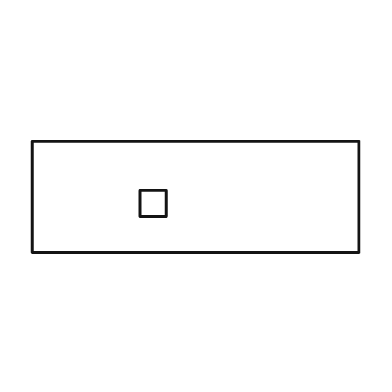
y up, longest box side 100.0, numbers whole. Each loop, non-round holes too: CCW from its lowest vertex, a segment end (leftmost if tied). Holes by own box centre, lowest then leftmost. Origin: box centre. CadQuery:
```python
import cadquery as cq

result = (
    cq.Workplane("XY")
    .moveTo(-50.0, -17.0)
    .lineTo(50.0, -17.0)
    .lineTo(50.0, 17.0)
    .lineTo(-50.0, 17.0)
    .close()
    .moveTo(-17.0, -6.0)
    .lineTo(-9.0, -6.0)
    .lineTo(-9.0, 2.0)
    .lineTo(-17.0, 2.0)
    .close()
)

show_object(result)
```